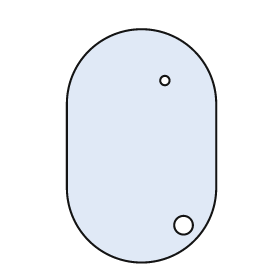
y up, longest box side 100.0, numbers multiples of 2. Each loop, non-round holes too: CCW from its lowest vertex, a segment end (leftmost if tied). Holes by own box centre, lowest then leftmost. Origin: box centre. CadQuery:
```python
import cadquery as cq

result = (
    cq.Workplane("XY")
    .moveTo(-32.0, -18.0)
    .threePointArc((0.0, -50.0), (32.0, -18.0))
    .lineTo(32.0, 18.0)
    .threePointArc((0.0, 50.0), (-32.0, 18.0))
    .close()
    .moveTo(18.0, -34.0)
    .circle(4.0)
    .moveTo(10.0, 28.0)
    .circle(2.0)
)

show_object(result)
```